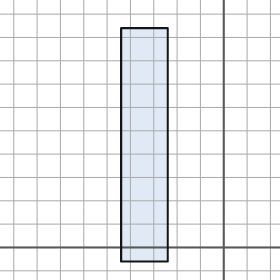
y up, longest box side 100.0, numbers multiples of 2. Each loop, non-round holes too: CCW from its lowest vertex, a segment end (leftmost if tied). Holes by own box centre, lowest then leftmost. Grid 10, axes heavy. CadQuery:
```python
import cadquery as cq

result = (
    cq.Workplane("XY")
    .moveTo(-44.0, -6.0)
    .lineTo(-24.0, -6.0)
    .lineTo(-24.0, 94.0)
    .lineTo(-44.0, 94.0)
    .close()
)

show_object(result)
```